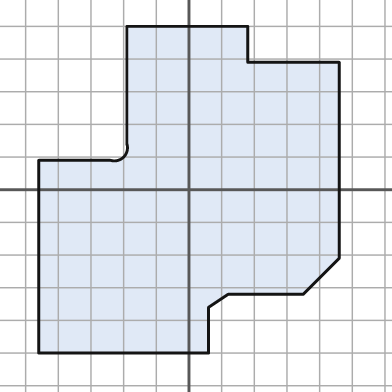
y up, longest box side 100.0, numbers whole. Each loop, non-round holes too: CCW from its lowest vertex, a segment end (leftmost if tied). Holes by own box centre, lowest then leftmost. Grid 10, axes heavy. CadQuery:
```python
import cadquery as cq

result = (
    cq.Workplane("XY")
    .moveTo(-46.0, -50.0)
    .lineTo(6.0, -50.0)
    .lineTo(6.0, -36.0)
    .lineTo(12.0, -32.0)
    .lineTo(35.0, -32.0)
    .lineTo(46.0, -21.0)
    .lineTo(46.0, 39.0)
    .lineTo(18.0, 39.0)
    .lineTo(18.0, 50.0)
    .lineTo(-19.0, 50.0)
    .lineTo(-19.0, 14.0)
    .threePointArc((-20.0, 10.0), (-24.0, 9.0))
    .lineTo(-46.0, 9.0)
    .close()
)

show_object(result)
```